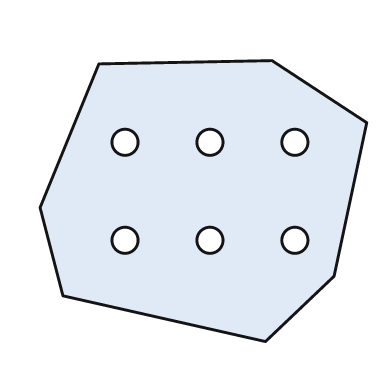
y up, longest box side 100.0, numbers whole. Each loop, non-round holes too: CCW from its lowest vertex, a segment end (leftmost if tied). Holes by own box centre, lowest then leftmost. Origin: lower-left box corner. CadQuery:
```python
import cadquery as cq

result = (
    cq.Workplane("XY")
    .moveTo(69.0, 0.0)
    .lineTo(90.0, 20.0)
    .lineTo(100.0, 67.0)
    .lineTo(71.0, 86.0)
    .lineTo(18.0, 85.0)
    .lineTo(0.0, 41.0)
    .lineTo(7.0, 14.0)
    .close()
    .moveTo(26.0, 31.0)
    .circle(4.0)
    .moveTo(52.0, 31.0)
    .circle(4.0)
    .moveTo(78.0, 31.0)
    .circle(4.0)
    .moveTo(26.0, 61.0)
    .circle(4.0)
    .moveTo(52.0, 61.0)
    .circle(4.0)
    .moveTo(78.0, 61.0)
    .circle(4.0)
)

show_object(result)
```